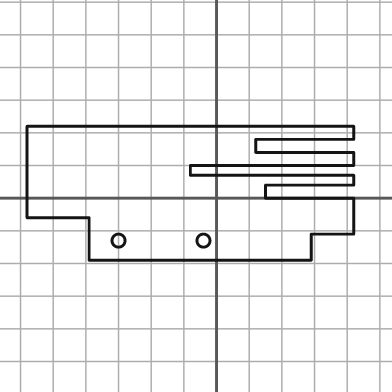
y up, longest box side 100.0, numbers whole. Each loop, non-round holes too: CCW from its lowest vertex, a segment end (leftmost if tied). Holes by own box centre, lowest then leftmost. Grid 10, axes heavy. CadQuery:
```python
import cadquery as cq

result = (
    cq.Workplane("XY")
    .moveTo(-39.0, -19.0)
    .lineTo(29.0, -19.0)
    .lineTo(29.0, -11.0)
    .lineTo(42.0, -11.0)
    .lineTo(42.0, 0.0)
    .lineTo(15.0, 0.0)
    .lineTo(15.0, 4.0)
    .lineTo(42.0, 4.0)
    .lineTo(42.0, 7.0)
    .lineTo(-8.0, 7.0)
    .lineTo(-8.0, 10.0)
    .lineTo(42.0, 10.0)
    .lineTo(42.0, 14.0)
    .lineTo(12.0, 14.0)
    .lineTo(12.0, 18.0)
    .lineTo(42.0, 18.0)
    .lineTo(42.0, 22.0)
    .lineTo(-58.0, 22.0)
    .lineTo(-58.0, -6.0)
    .lineTo(-39.0, -6.0)
    .close()
    .moveTo(-30.0, -13.0)
    .circle(2.0)
    .moveTo(-4.0, -13.0)
    .circle(2.0)
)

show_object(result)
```